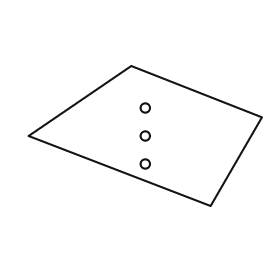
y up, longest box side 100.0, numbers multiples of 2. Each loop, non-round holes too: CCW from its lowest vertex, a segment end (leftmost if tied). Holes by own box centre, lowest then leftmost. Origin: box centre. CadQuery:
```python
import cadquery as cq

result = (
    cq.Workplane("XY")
    .moveTo(28.0, -30.0)
    .lineTo(50.0, 8.0)
    .lineTo(-6.0, 30.0)
    .lineTo(-50.0, 0.0)
    .close()
    .moveTo(0.0, -12.0)
    .circle(2.0)
    .moveTo(0.0, 0.0)
    .circle(2.0)
    .moveTo(0.0, 12.0)
    .circle(2.0)
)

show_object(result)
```